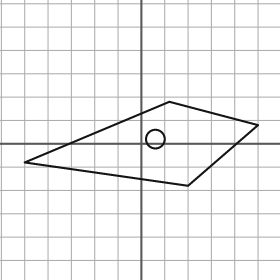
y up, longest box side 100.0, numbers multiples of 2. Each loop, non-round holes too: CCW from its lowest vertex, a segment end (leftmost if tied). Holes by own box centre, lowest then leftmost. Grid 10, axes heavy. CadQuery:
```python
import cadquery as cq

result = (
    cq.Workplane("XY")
    .moveTo(20.0, -18.0)
    .lineTo(50.0, 8.0)
    .lineTo(12.0, 18.0)
    .lineTo(-50.0, -8.0)
    .close()
    .moveTo(6.0, 2.0)
    .circle(4.0)
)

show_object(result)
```